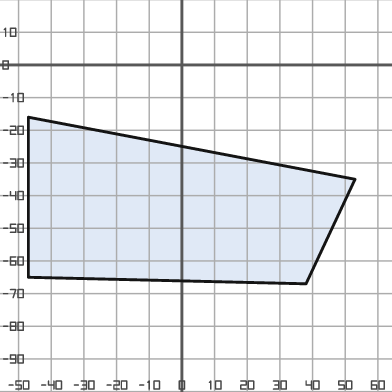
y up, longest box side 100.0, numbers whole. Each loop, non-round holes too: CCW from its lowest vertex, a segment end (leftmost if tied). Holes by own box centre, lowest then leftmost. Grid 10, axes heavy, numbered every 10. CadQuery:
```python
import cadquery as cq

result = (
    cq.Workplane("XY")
    .moveTo(38.0, -67.0)
    .lineTo(53.0, -35.0)
    .lineTo(-47.0, -16.0)
    .lineTo(-47.0, -65.0)
    .close()
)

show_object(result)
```